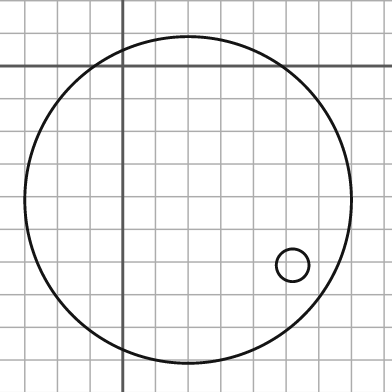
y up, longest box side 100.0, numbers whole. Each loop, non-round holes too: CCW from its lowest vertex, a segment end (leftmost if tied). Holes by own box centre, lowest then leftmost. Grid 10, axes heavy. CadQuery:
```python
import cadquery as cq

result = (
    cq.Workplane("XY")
    .moveTo(20.0, -41.0)
    .circle(50.0)
    .moveTo(52.0, -61.0)
    .circle(5.0)
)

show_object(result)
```